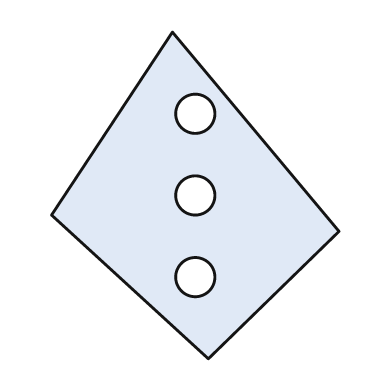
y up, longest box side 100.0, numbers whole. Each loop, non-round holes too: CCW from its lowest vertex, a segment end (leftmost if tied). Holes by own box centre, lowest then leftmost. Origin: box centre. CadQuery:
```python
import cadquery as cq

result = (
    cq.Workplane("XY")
    .moveTo(4.0, -50.0)
    .lineTo(44.0, -11.0)
    .lineTo(-7.0, 50.0)
    .lineTo(-44.0, -6.0)
    .close()
    .moveTo(0.0, -25.0)
    .circle(6.0)
    .moveTo(0.0, 0.0)
    .circle(6.0)
    .moveTo(0.0, 25.0)
    .circle(6.0)
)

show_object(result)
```